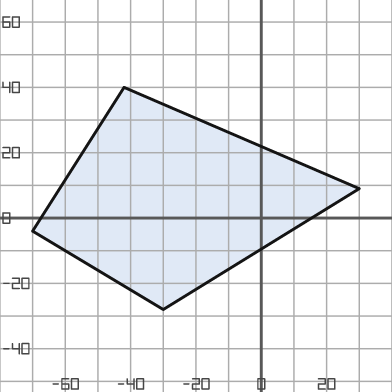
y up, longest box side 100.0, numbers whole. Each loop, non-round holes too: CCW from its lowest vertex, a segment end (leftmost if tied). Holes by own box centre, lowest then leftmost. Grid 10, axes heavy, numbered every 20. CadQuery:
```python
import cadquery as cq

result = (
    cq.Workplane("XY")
    .moveTo(-30.0, -28.0)
    .lineTo(30.0, 9.0)
    .lineTo(-42.0, 40.0)
    .lineTo(-70.0, -4.0)
    .close()
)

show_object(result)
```